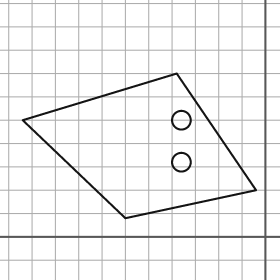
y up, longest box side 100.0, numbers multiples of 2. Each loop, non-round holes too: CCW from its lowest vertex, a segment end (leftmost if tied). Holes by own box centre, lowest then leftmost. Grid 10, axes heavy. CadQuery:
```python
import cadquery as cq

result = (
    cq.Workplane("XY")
    .moveTo(-60.0, 8.0)
    .lineTo(-4.0, 20.0)
    .lineTo(-38.0, 70.0)
    .lineTo(-104.0, 50.0)
    .close()
    .moveTo(-36.0, 32.0)
    .circle(4.0)
    .moveTo(-36.0, 50.0)
    .circle(4.0)
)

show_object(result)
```